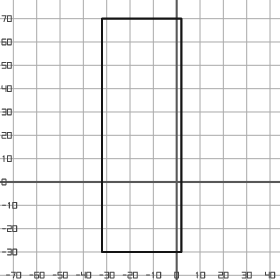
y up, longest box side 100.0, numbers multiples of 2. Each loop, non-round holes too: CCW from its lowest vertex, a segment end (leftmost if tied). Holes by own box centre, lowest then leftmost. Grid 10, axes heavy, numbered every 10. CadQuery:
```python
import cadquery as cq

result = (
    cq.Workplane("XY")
    .moveTo(-32.0, -30.0)
    .lineTo(2.0, -30.0)
    .lineTo(2.0, 70.0)
    .lineTo(-32.0, 70.0)
    .close()
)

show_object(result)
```